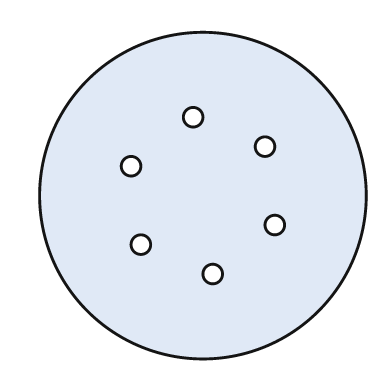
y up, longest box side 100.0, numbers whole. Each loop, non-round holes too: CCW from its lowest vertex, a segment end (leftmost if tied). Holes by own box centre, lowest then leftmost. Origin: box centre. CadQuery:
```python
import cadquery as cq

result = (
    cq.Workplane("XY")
    .moveTo(0.0, 0.0)
    .circle(50.0)
    .moveTo(3.0, -24.0)
    .circle(3.0)
    .moveTo(-19.0, -15.0)
    .circle(3.0)
    .moveTo(22.0, -9.0)
    .circle(3.0)
    .moveTo(-22.0, 9.0)
    .circle(3.0)
    .moveTo(19.0, 15.0)
    .circle(3.0)
    .moveTo(-3.0, 24.0)
    .circle(3.0)
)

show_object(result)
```